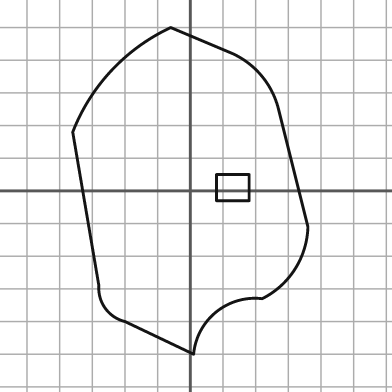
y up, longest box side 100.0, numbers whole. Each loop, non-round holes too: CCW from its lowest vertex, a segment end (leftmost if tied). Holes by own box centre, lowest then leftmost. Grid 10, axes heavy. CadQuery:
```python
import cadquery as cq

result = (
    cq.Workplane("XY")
    .moveTo(1.0, -50.0)
    .threePointArc((8.0, -37.0), (22.0, -33.0))
    .threePointArc((32.0, -24.0), (36.0, -11.0))
    .lineTo(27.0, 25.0)
    .threePointArc((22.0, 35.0), (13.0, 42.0))
    .lineTo(-6.0, 50.0)
    .threePointArc((-24.0, 37.0), (-36.0, 18.0))
    .lineTo(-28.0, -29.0)
    .threePointArc((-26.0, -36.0), (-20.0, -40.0))
    .close()
    .moveTo(8.0, -3.0)
    .lineTo(18.0, -3.0)
    .lineTo(18.0, 5.0)
    .lineTo(8.0, 5.0)
    .close()
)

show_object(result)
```